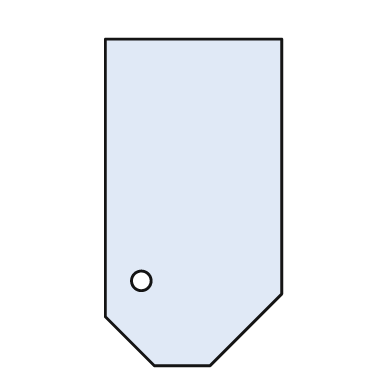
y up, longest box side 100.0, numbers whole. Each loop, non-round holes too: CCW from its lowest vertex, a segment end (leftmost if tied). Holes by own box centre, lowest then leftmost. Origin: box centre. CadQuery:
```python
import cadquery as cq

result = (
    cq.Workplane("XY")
    .moveTo(-12.0, -50.0)
    .lineTo(5.0, -50.0)
    .lineTo(27.0, -28.0)
    .lineTo(27.0, 50.0)
    .lineTo(-27.0, 50.0)
    .lineTo(-27.0, -35.0)
    .close()
    .moveTo(-16.0, -24.0)
    .circle(3.0)
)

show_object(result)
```